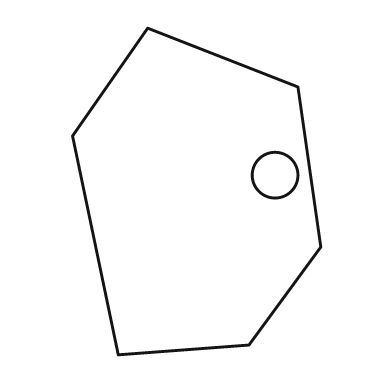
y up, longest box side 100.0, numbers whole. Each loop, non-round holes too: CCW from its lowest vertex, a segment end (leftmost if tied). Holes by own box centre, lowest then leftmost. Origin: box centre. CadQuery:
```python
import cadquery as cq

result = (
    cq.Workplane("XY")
    .moveTo(-24.0, -50.0)
    .lineTo(16.0, -47.0)
    .lineTo(38.0, -17.0)
    .lineTo(31.0, 32.0)
    .lineTo(-15.0, 50.0)
    .lineTo(-38.0, 17.0)
    .close()
    .moveTo(24.0, 5.0)
    .circle(7.0)
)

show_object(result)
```